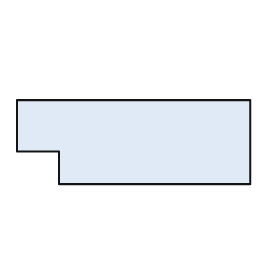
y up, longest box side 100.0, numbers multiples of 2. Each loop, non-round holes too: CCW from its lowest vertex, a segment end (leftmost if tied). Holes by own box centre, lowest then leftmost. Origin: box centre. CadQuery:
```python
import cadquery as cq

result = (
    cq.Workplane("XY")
    .moveTo(-32.0, -18.0)
    .lineTo(50.0, -18.0)
    .lineTo(50.0, 18.0)
    .lineTo(-50.0, 18.0)
    .lineTo(-50.0, -4.0)
    .lineTo(-32.0, -4.0)
    .close()
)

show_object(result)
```